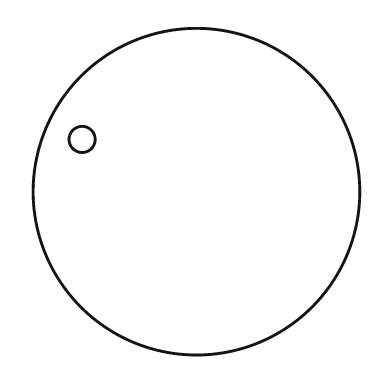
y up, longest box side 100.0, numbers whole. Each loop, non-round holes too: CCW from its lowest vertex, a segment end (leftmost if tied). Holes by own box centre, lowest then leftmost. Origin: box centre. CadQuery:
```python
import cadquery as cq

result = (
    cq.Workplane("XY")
    .moveTo(0.0, 0.0)
    .circle(50.0)
    .moveTo(-35.0, 16.0)
    .circle(4.0)
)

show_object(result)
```